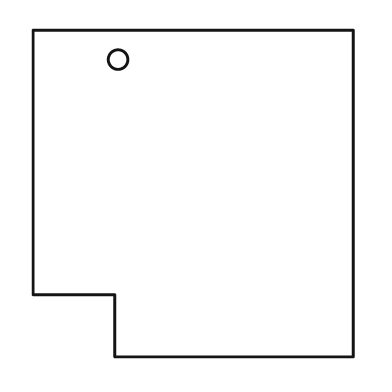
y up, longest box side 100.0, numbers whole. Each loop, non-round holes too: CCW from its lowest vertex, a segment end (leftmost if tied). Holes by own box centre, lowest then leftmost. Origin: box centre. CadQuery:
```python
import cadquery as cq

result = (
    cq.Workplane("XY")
    .moveTo(-24.0, -50.0)
    .lineTo(49.0, -50.0)
    .lineTo(49.0, 50.0)
    .lineTo(-49.0, 50.0)
    .lineTo(-49.0, -31.0)
    .lineTo(-24.0, -31.0)
    .close()
    .moveTo(-23.0, 41.0)
    .circle(3.0)
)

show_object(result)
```